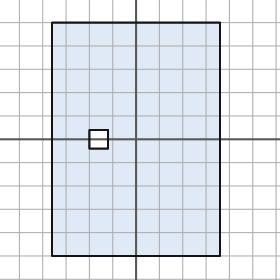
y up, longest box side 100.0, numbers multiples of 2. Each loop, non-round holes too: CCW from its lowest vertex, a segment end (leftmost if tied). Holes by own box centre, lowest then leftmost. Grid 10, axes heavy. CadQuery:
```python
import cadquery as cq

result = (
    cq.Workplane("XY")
    .moveTo(-36.0, -50.0)
    .lineTo(36.0, -50.0)
    .lineTo(36.0, 50.0)
    .lineTo(-36.0, 50.0)
    .close()
    .moveTo(-20.0, -4.0)
    .lineTo(-12.0, -4.0)
    .lineTo(-12.0, 4.0)
    .lineTo(-20.0, 4.0)
    .close()
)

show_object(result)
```